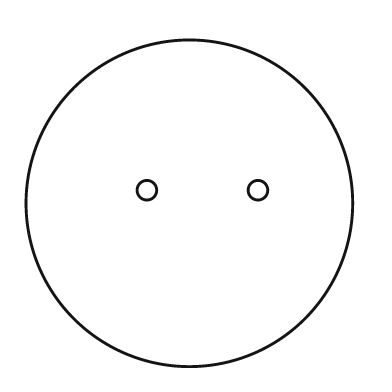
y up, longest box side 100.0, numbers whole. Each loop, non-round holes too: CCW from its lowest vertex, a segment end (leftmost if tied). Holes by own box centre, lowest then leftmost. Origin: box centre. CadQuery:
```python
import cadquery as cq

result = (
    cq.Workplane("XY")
    .moveTo(0.0, 0.0)
    .circle(50.0)
    .moveTo(-13.0, 4.0)
    .circle(3.0)
    .moveTo(21.0, 4.0)
    .circle(3.0)
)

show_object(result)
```